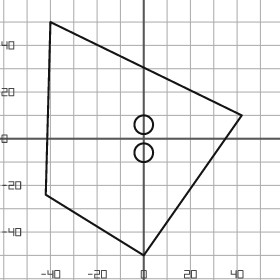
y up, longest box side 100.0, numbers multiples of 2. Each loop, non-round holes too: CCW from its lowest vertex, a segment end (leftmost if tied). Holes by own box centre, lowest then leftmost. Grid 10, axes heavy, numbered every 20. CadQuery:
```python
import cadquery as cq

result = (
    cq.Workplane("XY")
    .moveTo(0.0, -50.0)
    .lineTo(42.0, 10.0)
    .lineTo(-40.0, 50.0)
    .lineTo(-42.0, -24.0)
    .close()
    .moveTo(0.0, -6.0)
    .circle(4.0)
    .moveTo(0.0, 6.0)
    .circle(4.0)
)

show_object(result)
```